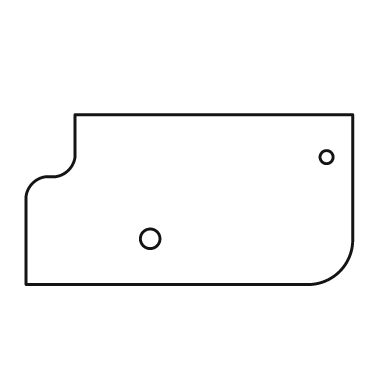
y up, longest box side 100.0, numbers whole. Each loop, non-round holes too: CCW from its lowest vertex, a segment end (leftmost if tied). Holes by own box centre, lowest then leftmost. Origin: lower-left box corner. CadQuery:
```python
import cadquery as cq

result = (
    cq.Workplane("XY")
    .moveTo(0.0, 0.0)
    .lineTo(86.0, 0.0)
    .threePointArc((96.0, 4.0), (100.0, 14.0))
    .lineTo(100.0, 52.0)
    .lineTo(15.0, 52.0)
    .lineTo(15.0, 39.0)
    .threePointArc((13.0, 35.0), (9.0, 33.0))
    .lineTo(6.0, 33.0)
    .threePointArc((2.0, 31.0), (0.0, 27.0))
    .close()
    .moveTo(38.0, 14.0)
    .circle(3.0)
    .moveTo(92.0, 39.0)
    .circle(2.0)
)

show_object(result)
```